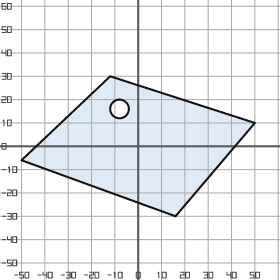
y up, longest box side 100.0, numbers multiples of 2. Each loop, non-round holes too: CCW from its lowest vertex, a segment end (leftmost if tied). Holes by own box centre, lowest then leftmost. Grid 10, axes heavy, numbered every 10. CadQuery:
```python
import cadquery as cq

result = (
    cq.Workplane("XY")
    .moveTo(16.0, -30.0)
    .lineTo(50.0, 10.0)
    .lineTo(-12.0, 30.0)
    .lineTo(-50.0, -6.0)
    .close()
    .moveTo(-8.0, 16.0)
    .circle(4.0)
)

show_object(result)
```